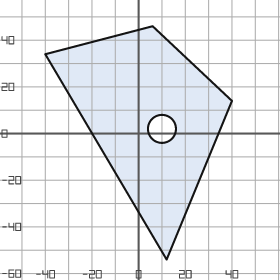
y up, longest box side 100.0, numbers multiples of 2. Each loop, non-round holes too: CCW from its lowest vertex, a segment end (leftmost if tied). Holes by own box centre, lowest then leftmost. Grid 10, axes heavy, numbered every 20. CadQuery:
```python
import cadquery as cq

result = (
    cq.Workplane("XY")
    .moveTo(12.0, -54.0)
    .lineTo(40.0, 14.0)
    .lineTo(6.0, 46.0)
    .lineTo(-40.0, 34.0)
    .close()
    .moveTo(10.0, 2.0)
    .circle(6.0)
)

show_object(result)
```